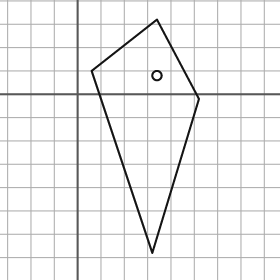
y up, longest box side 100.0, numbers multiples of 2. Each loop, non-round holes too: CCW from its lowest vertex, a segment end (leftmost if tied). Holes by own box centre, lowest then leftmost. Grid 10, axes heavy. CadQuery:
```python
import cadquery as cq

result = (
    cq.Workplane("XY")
    .moveTo(32.0, -68.0)
    .lineTo(52.0, -2.0)
    .lineTo(34.0, 32.0)
    .lineTo(6.0, 10.0)
    .close()
    .moveTo(34.0, 8.0)
    .circle(2.0)
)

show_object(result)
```